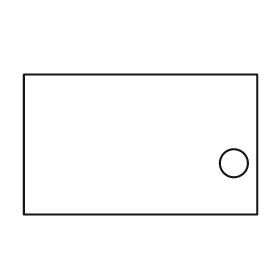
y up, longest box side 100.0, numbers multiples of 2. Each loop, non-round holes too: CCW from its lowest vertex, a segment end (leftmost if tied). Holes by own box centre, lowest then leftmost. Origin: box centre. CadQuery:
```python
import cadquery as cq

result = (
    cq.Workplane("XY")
    .moveTo(-50.0, -30.0)
    .lineTo(50.0, -30.0)
    .lineTo(50.0, 30.0)
    .lineTo(-50.0, 30.0)
    .close()
    .moveTo(40.0, -8.0)
    .circle(6.0)
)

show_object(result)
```